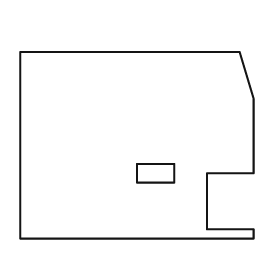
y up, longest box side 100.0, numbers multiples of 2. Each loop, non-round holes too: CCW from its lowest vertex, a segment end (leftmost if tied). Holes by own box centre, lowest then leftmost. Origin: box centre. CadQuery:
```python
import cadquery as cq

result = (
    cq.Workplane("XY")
    .moveTo(-50.0, -40.0)
    .lineTo(50.0, -40.0)
    .lineTo(50.0, -36.0)
    .lineTo(30.0, -36.0)
    .lineTo(30.0, -12.0)
    .lineTo(50.0, -12.0)
    .lineTo(50.0, 20.0)
    .lineTo(44.0, 40.0)
    .lineTo(-50.0, 40.0)
    .close()
    .moveTo(0.0, -16.0)
    .lineTo(16.0, -16.0)
    .lineTo(16.0, -8.0)
    .lineTo(0.0, -8.0)
    .close()
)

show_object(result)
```